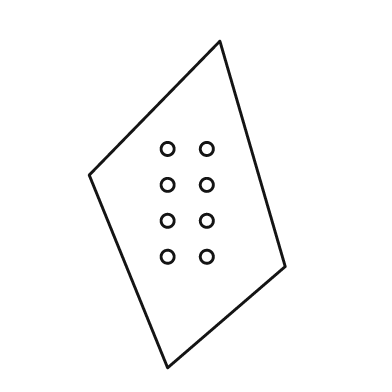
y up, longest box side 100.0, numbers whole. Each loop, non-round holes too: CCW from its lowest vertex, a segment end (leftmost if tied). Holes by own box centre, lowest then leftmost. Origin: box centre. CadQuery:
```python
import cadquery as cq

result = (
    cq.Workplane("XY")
    .moveTo(-6.0, -50.0)
    .lineTo(30.0, -19.0)
    .lineTo(10.0, 50.0)
    .lineTo(-30.0, 9.0)
    .close()
    .moveTo(-6.0, -16.0)
    .circle(2.0)
    .moveTo(6.0, -16.0)
    .circle(2.0)
    .moveTo(-6.0, -5.0)
    .circle(2.0)
    .moveTo(6.0, -5.0)
    .circle(2.0)
    .moveTo(-6.0, 6.0)
    .circle(2.0)
    .moveTo(6.0, 6.0)
    .circle(2.0)
    .moveTo(-6.0, 17.0)
    .circle(2.0)
    .moveTo(6.0, 17.0)
    .circle(2.0)
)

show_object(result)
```